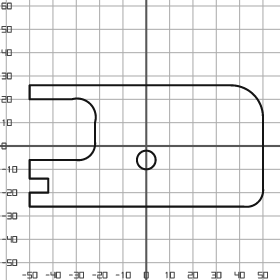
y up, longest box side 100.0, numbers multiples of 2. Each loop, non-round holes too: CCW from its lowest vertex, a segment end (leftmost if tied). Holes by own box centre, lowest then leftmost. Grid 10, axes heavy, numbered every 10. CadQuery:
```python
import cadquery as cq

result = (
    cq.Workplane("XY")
    .moveTo(-50.0, -26.0)
    .lineTo(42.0, -26.0)
    .threePointArc((48.0, -24.0), (50.0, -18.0))
    .lineTo(50.0, 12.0)
    .threePointArc((46.0, 22.0), (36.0, 26.0))
    .lineTo(-50.0, 26.0)
    .lineTo(-50.0, 20.0)
    .lineTo(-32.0, 20.0)
    .threePointArc((-24.0, 18.0), (-22.0, 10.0))
    .lineTo(-22.0, 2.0)
    .threePointArc((-24.0, -4.0), (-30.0, -6.0))
    .lineTo(-50.0, -6.0)
    .lineTo(-50.0, -14.0)
    .lineTo(-42.0, -14.0)
    .lineTo(-42.0, -20.0)
    .lineTo(-50.0, -20.0)
    .close()
    .moveTo(0.0, -6.0)
    .circle(4.0)
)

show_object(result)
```